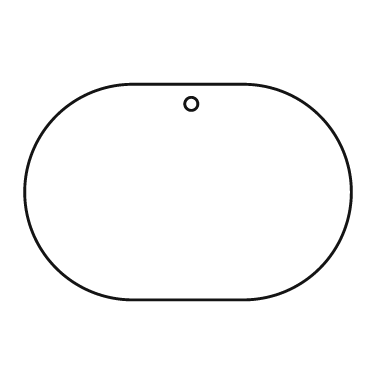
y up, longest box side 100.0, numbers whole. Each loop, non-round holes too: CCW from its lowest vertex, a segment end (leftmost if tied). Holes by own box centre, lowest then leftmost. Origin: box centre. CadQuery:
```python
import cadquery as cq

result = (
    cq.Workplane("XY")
    .moveTo(-17.0, -33.0)
    .lineTo(17.0, -33.0)
    .threePointArc((50.0, 0.0), (17.0, 33.0))
    .lineTo(-17.0, 33.0)
    .threePointArc((-50.0, 0.0), (-17.0, -33.0))
    .close()
    .moveTo(1.0, 27.0)
    .circle(2.0)
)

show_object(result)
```